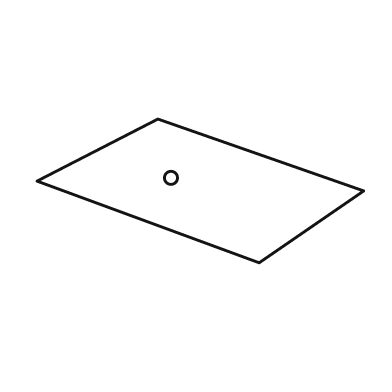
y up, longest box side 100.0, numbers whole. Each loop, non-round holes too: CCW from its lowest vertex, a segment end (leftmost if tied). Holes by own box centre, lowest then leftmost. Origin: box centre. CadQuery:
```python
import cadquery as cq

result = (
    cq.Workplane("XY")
    .moveTo(18.0, -22.0)
    .lineTo(50.0, 0.0)
    .lineTo(-13.0, 22.0)
    .lineTo(-50.0, 3.0)
    .close()
    .moveTo(-9.0, 4.0)
    .circle(2.0)
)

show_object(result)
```